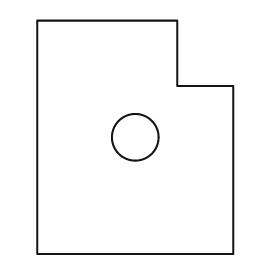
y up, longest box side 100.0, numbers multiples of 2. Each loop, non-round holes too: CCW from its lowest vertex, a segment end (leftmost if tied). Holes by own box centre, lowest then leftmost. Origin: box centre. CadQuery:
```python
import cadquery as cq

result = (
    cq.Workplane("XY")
    .moveTo(-42.0, -50.0)
    .lineTo(42.0, -50.0)
    .lineTo(42.0, 22.0)
    .lineTo(18.0, 22.0)
    .lineTo(18.0, 50.0)
    .lineTo(-42.0, 50.0)
    .close()
    .moveTo(0.0, 0.0)
    .circle(10.0)
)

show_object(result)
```